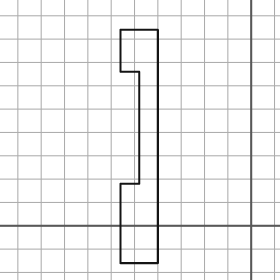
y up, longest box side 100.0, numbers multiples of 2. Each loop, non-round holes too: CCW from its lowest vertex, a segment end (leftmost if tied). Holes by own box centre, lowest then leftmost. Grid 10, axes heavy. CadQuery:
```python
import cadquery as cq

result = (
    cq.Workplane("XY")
    .moveTo(-56.0, -16.0)
    .lineTo(-40.0, -16.0)
    .lineTo(-40.0, 84.0)
    .lineTo(-56.0, 84.0)
    .lineTo(-56.0, 66.0)
    .lineTo(-48.0, 66.0)
    .lineTo(-48.0, 18.0)
    .lineTo(-56.0, 18.0)
    .close()
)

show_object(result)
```